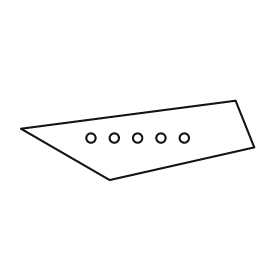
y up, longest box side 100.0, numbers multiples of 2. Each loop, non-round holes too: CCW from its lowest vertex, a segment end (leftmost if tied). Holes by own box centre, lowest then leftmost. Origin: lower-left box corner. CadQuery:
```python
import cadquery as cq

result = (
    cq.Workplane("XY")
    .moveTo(38.0, 0.0)
    .lineTo(100.0, 14.0)
    .lineTo(92.0, 34.0)
    .lineTo(0.0, 22.0)
    .close()
    .moveTo(30.0, 18.0)
    .circle(2.0)
    .moveTo(40.0, 18.0)
    .circle(2.0)
    .moveTo(50.0, 18.0)
    .circle(2.0)
    .moveTo(60.0, 18.0)
    .circle(2.0)
    .moveTo(70.0, 18.0)
    .circle(2.0)
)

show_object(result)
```